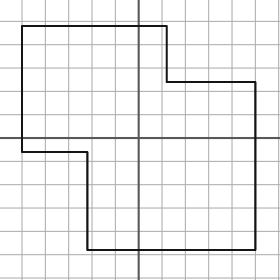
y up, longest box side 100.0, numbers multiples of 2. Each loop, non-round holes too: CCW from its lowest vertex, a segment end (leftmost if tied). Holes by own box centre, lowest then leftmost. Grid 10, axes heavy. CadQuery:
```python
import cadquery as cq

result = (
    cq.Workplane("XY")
    .moveTo(-22.0, -48.0)
    .lineTo(50.0, -48.0)
    .lineTo(50.0, 24.0)
    .lineTo(12.0, 24.0)
    .lineTo(12.0, 48.0)
    .lineTo(-50.0, 48.0)
    .lineTo(-50.0, -6.0)
    .lineTo(-22.0, -6.0)
    .close()
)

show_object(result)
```